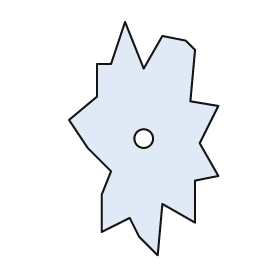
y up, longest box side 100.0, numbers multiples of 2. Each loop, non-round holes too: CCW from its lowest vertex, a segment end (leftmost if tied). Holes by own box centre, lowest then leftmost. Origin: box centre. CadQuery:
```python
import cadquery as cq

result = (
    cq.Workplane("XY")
    .moveTo(6.0, -50.0)
    .lineTo(8.0, -28.0)
    .lineTo(22.0, -36.0)
    .lineTo(22.0, -18.0)
    .lineTo(32.0, -16.0)
    .lineTo(24.0, -2.0)
    .lineTo(32.0, 14.0)
    .lineTo(20.0, 16.0)
    .lineTo(22.0, 38.0)
    .lineTo(18.0, 42.0)
    .lineTo(8.0, 44.0)
    .lineTo(0.0, 30.0)
    .lineTo(-8.0, 50.0)
    .lineTo(-14.0, 32.0)
    .lineTo(-20.0, 32.0)
    .lineTo(-20.0, 18.0)
    .lineTo(-32.0, 8.0)
    .lineTo(-24.0, -4.0)
    .lineTo(-14.0, -14.0)
    .lineTo(-18.0, -24.0)
    .lineTo(-18.0, -40.0)
    .lineTo(-6.0, -34.0)
    .lineTo(-2.0, -42.0)
    .close()
    .moveTo(0.0, 0.0)
    .circle(4.0)
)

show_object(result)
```